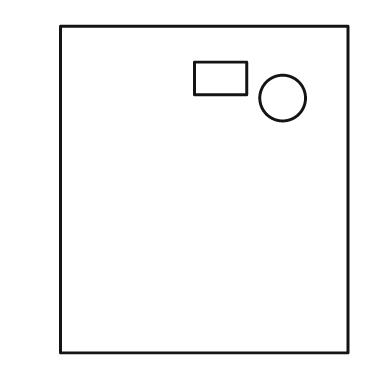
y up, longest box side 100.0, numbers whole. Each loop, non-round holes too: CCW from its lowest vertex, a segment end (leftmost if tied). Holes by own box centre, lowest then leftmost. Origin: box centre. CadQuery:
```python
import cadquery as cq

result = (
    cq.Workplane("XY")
    .moveTo(-44.0, -50.0)
    .lineTo(44.0, -50.0)
    .lineTo(44.0, 50.0)
    .lineTo(-44.0, 50.0)
    .close()
    .moveTo(24.0, 28.0)
    .circle(7.0)
    .moveTo(-3.0, 29.0)
    .lineTo(13.0, 29.0)
    .lineTo(13.0, 39.0)
    .lineTo(-3.0, 39.0)
    .close()
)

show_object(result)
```